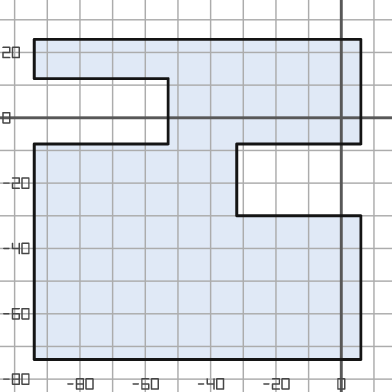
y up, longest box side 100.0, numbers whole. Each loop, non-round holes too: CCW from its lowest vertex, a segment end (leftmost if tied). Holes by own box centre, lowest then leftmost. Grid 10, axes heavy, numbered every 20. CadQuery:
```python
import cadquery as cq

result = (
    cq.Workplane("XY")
    .moveTo(-94.0, -74.0)
    .lineTo(6.0, -74.0)
    .lineTo(6.0, -30.0)
    .lineTo(-32.0, -30.0)
    .lineTo(-32.0, -8.0)
    .lineTo(6.0, -8.0)
    .lineTo(6.0, 24.0)
    .lineTo(-94.0, 24.0)
    .lineTo(-94.0, 12.0)
    .lineTo(-53.0, 12.0)
    .lineTo(-53.0, -8.0)
    .lineTo(-94.0, -8.0)
    .close()
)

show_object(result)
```